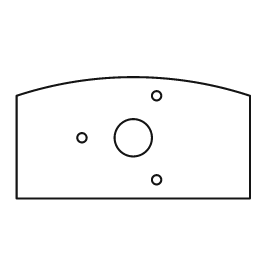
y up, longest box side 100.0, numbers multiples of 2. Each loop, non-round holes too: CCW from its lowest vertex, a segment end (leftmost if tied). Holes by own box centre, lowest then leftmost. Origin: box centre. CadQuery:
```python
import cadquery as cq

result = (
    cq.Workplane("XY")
    .moveTo(-50.0, -26.0)
    .lineTo(50.0, -26.0)
    .lineTo(50.0, 18.0)
    .threePointArc((0.0, 26.0), (-50.0, 18.0))
    .close()
    .moveTo(10.0, -18.0)
    .circle(2.0)
    .moveTo(-22.0, 0.0)
    .circle(2.0)
    .moveTo(0.0, 0.0)
    .circle(8.0)
    .moveTo(10.0, 18.0)
    .circle(2.0)
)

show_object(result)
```